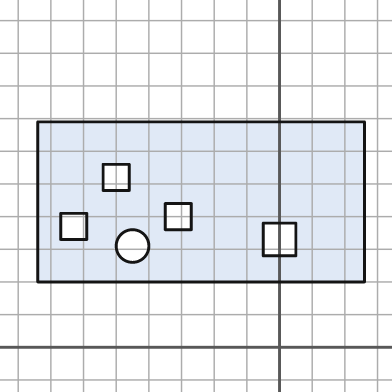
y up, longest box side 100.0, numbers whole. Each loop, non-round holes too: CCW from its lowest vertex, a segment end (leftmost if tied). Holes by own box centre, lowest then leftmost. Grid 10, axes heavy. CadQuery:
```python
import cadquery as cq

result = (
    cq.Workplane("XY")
    .moveTo(-74.0, 20.0)
    .lineTo(26.0, 20.0)
    .lineTo(26.0, 69.0)
    .lineTo(-74.0, 69.0)
    .close()
    .moveTo(-45.0, 31.0)
    .circle(5.0)
    .moveTo(-5.0, 28.0)
    .lineTo(5.0, 28.0)
    .lineTo(5.0, 38.0)
    .lineTo(-5.0, 38.0)
    .close()
    .moveTo(-67.0, 33.0)
    .lineTo(-59.0, 33.0)
    .lineTo(-59.0, 41.0)
    .lineTo(-67.0, 41.0)
    .close()
    .moveTo(-35.0, 36.0)
    .lineTo(-27.0, 36.0)
    .lineTo(-27.0, 44.0)
    .lineTo(-35.0, 44.0)
    .close()
    .moveTo(-54.0, 48.0)
    .lineTo(-46.0, 48.0)
    .lineTo(-46.0, 56.0)
    .lineTo(-54.0, 56.0)
    .close()
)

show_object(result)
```